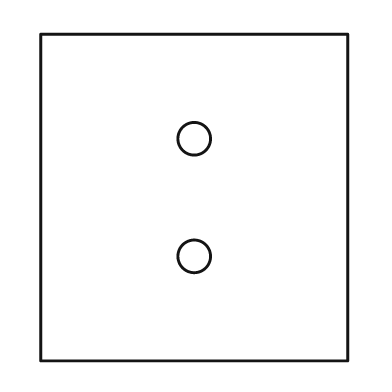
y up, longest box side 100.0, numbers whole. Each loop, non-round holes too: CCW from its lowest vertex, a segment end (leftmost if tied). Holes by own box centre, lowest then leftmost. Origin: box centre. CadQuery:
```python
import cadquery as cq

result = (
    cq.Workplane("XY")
    .moveTo(-47.0, -50.0)
    .lineTo(47.0, -50.0)
    .lineTo(47.0, 50.0)
    .lineTo(-47.0, 50.0)
    .close()
    .moveTo(0.0, -18.0)
    .circle(5.0)
    .moveTo(0.0, 18.0)
    .circle(5.0)
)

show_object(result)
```